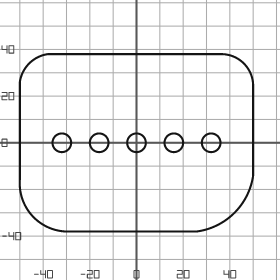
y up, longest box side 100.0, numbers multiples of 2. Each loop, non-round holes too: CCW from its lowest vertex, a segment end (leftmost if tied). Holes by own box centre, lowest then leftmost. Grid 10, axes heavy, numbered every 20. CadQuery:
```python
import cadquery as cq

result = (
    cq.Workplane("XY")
    .moveTo(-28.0, -38.0)
    .lineTo(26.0, -38.0)
    .threePointArc((42.0, -30.0), (50.0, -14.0))
    .lineTo(50.0, 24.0)
    .threePointArc((46.0, 34.0), (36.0, 38.0))
    .lineTo(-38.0, 38.0)
    .threePointArc((-46.0, 34.0), (-50.0, 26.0))
    .lineTo(-50.0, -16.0)
    .threePointArc((-44.0, -32.0), (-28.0, -38.0))
    .close()
    .moveTo(-32.0, 0.0)
    .circle(4.0)
    .moveTo(-16.0, 0.0)
    .circle(4.0)
    .moveTo(0.0, 0.0)
    .circle(4.0)
    .moveTo(16.0, 0.0)
    .circle(4.0)
    .moveTo(32.0, 0.0)
    .circle(4.0)
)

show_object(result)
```